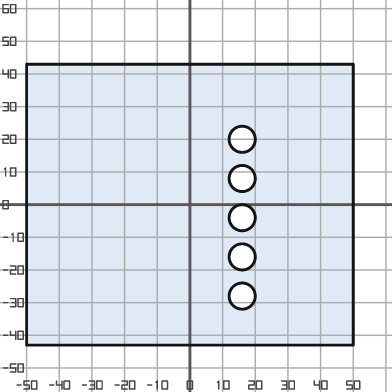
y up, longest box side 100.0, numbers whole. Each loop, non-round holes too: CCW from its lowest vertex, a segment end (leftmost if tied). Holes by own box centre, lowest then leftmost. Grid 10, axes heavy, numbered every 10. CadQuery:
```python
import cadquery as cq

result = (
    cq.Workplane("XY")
    .moveTo(-50.0, -43.0)
    .lineTo(50.0, -43.0)
    .lineTo(50.0, 43.0)
    .lineTo(-50.0, 43.0)
    .close()
    .moveTo(16.0, -28.0)
    .circle(4.0)
    .moveTo(16.0, -16.0)
    .circle(4.0)
    .moveTo(16.0, -4.0)
    .circle(4.0)
    .moveTo(16.0, 8.0)
    .circle(4.0)
    .moveTo(16.0, 20.0)
    .circle(4.0)
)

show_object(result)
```